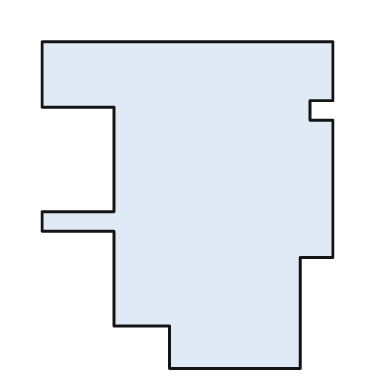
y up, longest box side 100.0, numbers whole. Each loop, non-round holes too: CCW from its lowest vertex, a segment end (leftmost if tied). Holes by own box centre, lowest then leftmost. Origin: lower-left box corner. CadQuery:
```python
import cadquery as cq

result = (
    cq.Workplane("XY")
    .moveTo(39.0, 0.0)
    .lineTo(79.0, 0.0)
    .lineTo(79.0, 34.0)
    .lineTo(89.0, 34.0)
    .lineTo(89.0, 76.0)
    .lineTo(82.0, 76.0)
    .lineTo(82.0, 82.0)
    .lineTo(89.0, 82.0)
    .lineTo(89.0, 100.0)
    .lineTo(0.0, 100.0)
    .lineTo(0.0, 80.0)
    .lineTo(22.0, 80.0)
    .lineTo(22.0, 48.0)
    .lineTo(0.0, 48.0)
    .lineTo(0.0, 42.0)
    .lineTo(22.0, 42.0)
    .lineTo(22.0, 13.0)
    .lineTo(39.0, 13.0)
    .close()
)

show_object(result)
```